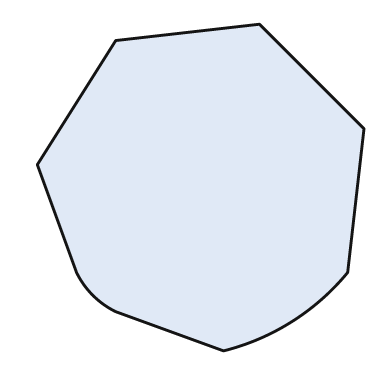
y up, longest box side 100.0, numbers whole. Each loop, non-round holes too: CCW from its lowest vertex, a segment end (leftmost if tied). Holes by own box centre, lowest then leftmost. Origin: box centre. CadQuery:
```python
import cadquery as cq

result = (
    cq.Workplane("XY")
    .moveTo(7.0, -50.0)
    .threePointArc((28.0, -41.0), (45.0, -26.0))
    .lineTo(50.0, 18.0)
    .lineTo(18.0, 50.0)
    .lineTo(-26.0, 45.0)
    .lineTo(-50.0, 7.0)
    .lineTo(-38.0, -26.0)
    .threePointArc((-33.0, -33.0), (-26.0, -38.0))
    .close()
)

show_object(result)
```